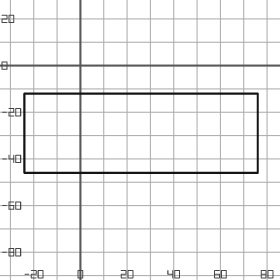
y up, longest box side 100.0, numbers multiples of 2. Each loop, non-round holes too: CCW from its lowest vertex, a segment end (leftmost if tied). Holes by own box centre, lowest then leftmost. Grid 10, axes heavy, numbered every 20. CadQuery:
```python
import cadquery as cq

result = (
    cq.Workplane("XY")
    .moveTo(-24.0, -46.0)
    .lineTo(76.0, -46.0)
    .lineTo(76.0, -12.0)
    .lineTo(-24.0, -12.0)
    .close()
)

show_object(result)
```